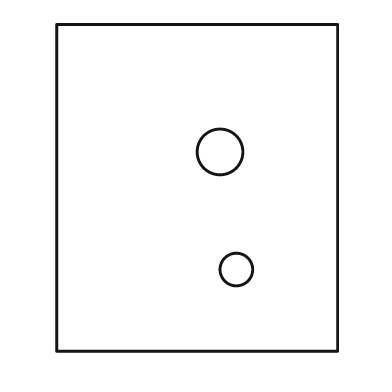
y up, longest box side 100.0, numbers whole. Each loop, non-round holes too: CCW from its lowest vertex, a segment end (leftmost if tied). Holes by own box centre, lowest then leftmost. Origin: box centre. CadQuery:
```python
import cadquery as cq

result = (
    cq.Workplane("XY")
    .moveTo(-43.0, -50.0)
    .lineTo(43.0, -50.0)
    .lineTo(43.0, 50.0)
    .lineTo(-43.0, 50.0)
    .close()
    .moveTo(12.0, -25.0)
    .circle(5.0)
    .moveTo(7.0, 11.0)
    .circle(7.0)
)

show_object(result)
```